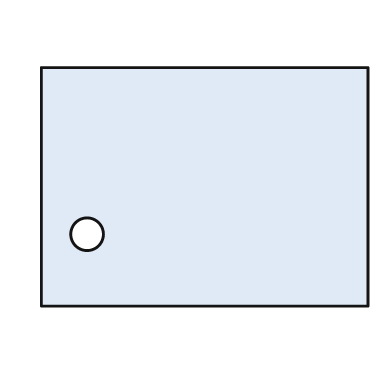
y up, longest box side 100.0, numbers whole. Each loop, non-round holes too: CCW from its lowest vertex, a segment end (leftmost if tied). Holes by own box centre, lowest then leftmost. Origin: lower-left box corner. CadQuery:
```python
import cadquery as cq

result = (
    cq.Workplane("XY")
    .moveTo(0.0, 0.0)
    .lineTo(100.0, 0.0)
    .lineTo(100.0, 73.0)
    .lineTo(0.0, 73.0)
    .close()
    .moveTo(14.0, 22.0)
    .circle(5.0)
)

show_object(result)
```